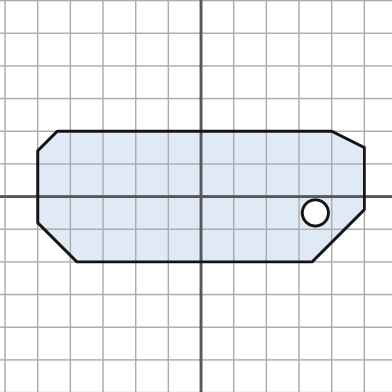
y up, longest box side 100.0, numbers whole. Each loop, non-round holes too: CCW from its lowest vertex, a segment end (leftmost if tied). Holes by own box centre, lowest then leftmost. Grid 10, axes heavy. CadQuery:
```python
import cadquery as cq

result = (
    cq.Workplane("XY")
    .moveTo(-38.0, -20.0)
    .lineTo(34.0, -20.0)
    .lineTo(50.0, -4.0)
    .lineTo(50.0, 15.0)
    .lineTo(40.0, 20.0)
    .lineTo(-44.0, 20.0)
    .lineTo(-50.0, 14.0)
    .lineTo(-50.0, -8.0)
    .close()
    .moveTo(35.0, -5.0)
    .circle(4.0)
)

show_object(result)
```